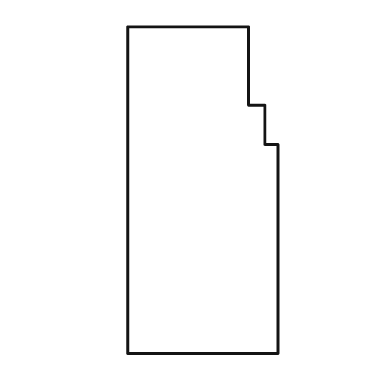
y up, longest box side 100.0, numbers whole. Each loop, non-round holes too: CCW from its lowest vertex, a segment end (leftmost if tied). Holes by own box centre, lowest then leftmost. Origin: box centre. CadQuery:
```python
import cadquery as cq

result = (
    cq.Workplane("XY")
    .moveTo(-23.0, -50.0)
    .lineTo(23.0, -50.0)
    .lineTo(23.0, 14.0)
    .lineTo(19.0, 14.0)
    .lineTo(19.0, 26.0)
    .lineTo(14.0, 26.0)
    .lineTo(14.0, 50.0)
    .lineTo(-23.0, 50.0)
    .close()
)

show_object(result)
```